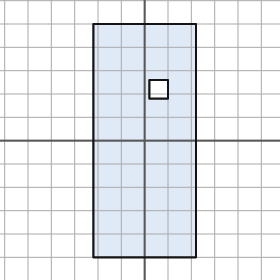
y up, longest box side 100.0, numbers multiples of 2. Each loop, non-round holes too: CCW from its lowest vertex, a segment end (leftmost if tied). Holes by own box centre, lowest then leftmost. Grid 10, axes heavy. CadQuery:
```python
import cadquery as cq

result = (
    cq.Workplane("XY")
    .moveTo(-22.0, -50.0)
    .lineTo(22.0, -50.0)
    .lineTo(22.0, 50.0)
    .lineTo(-22.0, 50.0)
    .close()
    .moveTo(2.0, 18.0)
    .lineTo(10.0, 18.0)
    .lineTo(10.0, 26.0)
    .lineTo(2.0, 26.0)
    .close()
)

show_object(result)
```